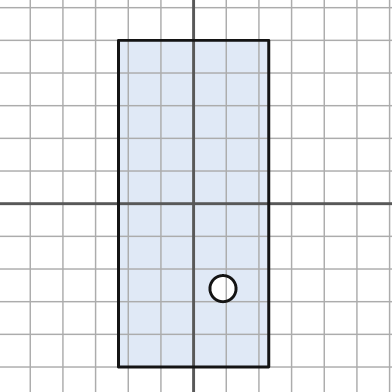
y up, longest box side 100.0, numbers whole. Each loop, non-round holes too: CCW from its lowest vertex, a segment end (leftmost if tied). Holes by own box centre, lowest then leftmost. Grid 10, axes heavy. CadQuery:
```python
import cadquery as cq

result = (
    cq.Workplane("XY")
    .moveTo(-23.0, -50.0)
    .lineTo(23.0, -50.0)
    .lineTo(23.0, 50.0)
    .lineTo(-23.0, 50.0)
    .close()
    .moveTo(9.0, -26.0)
    .circle(4.0)
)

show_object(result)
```